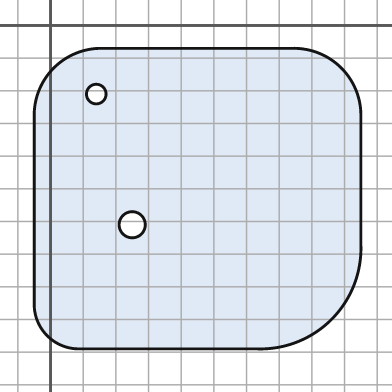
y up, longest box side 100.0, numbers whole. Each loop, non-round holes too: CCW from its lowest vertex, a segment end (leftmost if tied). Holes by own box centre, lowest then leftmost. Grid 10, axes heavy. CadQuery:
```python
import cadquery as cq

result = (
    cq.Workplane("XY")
    .moveTo(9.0, -99.0)
    .lineTo(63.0, -99.0)
    .threePointArc((86.0, -90.0), (95.0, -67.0))
    .lineTo(95.0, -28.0)
    .threePointArc((89.0, -13.0), (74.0, -7.0))
    .lineTo(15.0, -7.0)
    .threePointArc((1.0, -13.0), (-5.0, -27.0))
    .lineTo(-5.0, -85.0)
    .threePointArc((-1.0, -95.0), (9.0, -99.0))
    .close()
    .moveTo(25.0, -61.0)
    .circle(4.0)
    .moveTo(14.0, -21.0)
    .circle(3.0)
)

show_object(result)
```